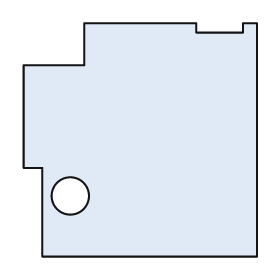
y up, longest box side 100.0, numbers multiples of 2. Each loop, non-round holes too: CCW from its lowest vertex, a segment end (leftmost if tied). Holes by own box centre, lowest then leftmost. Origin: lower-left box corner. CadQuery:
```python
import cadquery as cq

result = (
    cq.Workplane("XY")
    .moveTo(8.0, 0.0)
    .lineTo(100.0, 0.0)
    .lineTo(100.0, 100.0)
    .lineTo(94.0, 100.0)
    .lineTo(94.0, 96.0)
    .lineTo(74.0, 96.0)
    .lineTo(74.0, 100.0)
    .lineTo(26.0, 100.0)
    .lineTo(26.0, 82.0)
    .lineTo(0.0, 82.0)
    .lineTo(0.0, 38.0)
    .lineTo(8.0, 38.0)
    .close()
    .moveTo(20.0, 26.0)
    .circle(8.0)
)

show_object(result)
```